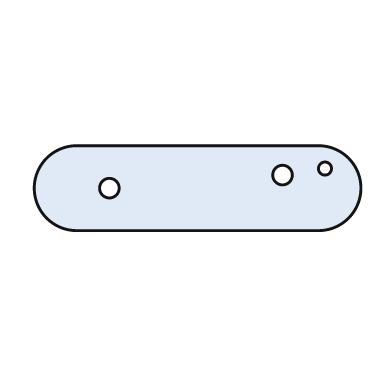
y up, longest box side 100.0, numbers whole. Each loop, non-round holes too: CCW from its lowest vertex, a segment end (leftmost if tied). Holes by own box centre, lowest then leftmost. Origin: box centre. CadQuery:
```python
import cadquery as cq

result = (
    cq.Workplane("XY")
    .moveTo(-37.0, -13.0)
    .lineTo(37.0, -13.0)
    .threePointArc((50.0, 0.0), (37.0, 13.0))
    .lineTo(-37.0, 13.0)
    .threePointArc((-50.0, 0.0), (-37.0, -13.0))
    .close()
    .moveTo(-27.0, 0.0)
    .circle(3.0)
    .moveTo(26.0, 4.0)
    .circle(3.0)
    .moveTo(39.0, 6.0)
    .circle(2.0)
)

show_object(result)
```